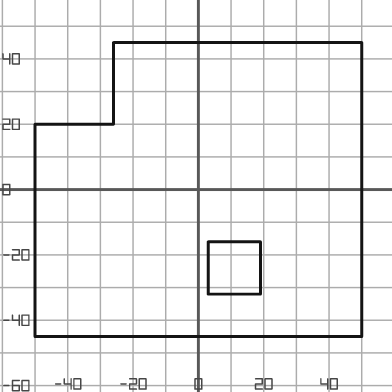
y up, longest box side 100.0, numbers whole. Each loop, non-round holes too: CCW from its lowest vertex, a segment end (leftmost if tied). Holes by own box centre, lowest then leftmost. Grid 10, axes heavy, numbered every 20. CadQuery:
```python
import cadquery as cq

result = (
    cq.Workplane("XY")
    .moveTo(-50.0, -45.0)
    .lineTo(50.0, -45.0)
    .lineTo(50.0, 45.0)
    .lineTo(-26.0, 45.0)
    .lineTo(-26.0, 20.0)
    .lineTo(-50.0, 20.0)
    .close()
    .moveTo(3.0, -32.0)
    .lineTo(19.0, -32.0)
    .lineTo(19.0, -16.0)
    .lineTo(3.0, -16.0)
    .close()
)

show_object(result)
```